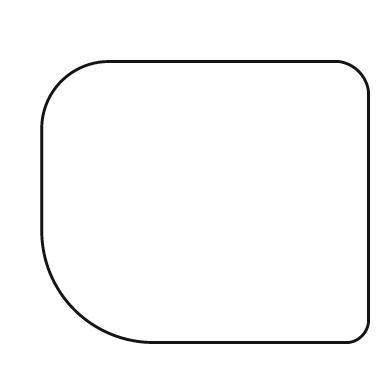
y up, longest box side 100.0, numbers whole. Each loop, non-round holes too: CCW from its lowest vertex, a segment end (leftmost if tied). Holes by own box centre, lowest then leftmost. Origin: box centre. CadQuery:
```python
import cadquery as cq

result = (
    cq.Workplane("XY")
    .moveTo(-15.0, -43.0)
    .lineTo(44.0, -43.0)
    .threePointArc((48.0, -41.0), (50.0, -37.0))
    .lineTo(50.0, 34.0)
    .threePointArc((47.0, 40.0), (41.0, 43.0))
    .lineTo(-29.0, 43.0)
    .threePointArc((-44.0, 37.0), (-50.0, 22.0))
    .lineTo(-50.0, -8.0)
    .threePointArc((-40.0, -33.0), (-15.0, -43.0))
    .close()
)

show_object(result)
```